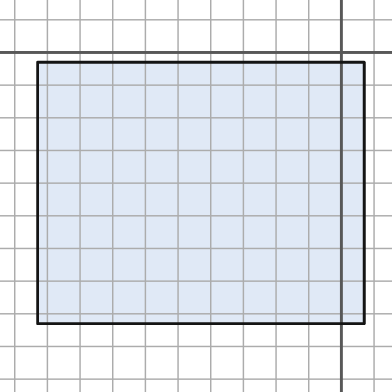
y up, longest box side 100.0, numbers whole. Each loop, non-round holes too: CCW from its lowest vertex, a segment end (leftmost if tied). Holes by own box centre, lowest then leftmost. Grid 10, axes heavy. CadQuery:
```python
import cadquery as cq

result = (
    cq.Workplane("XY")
    .moveTo(-93.0, -83.0)
    .lineTo(7.0, -83.0)
    .lineTo(7.0, -3.0)
    .lineTo(-93.0, -3.0)
    .close()
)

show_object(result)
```